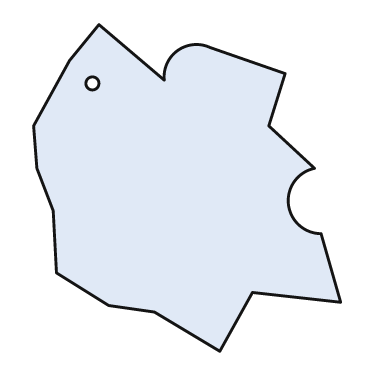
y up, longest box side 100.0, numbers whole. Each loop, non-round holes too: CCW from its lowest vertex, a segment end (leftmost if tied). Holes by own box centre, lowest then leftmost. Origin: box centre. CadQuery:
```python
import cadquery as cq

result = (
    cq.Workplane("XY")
    .moveTo(10.0, -50.0)
    .lineTo(20.0, -32.0)
    .lineTo(47.0, -35.0)
    .lineTo(41.0, -14.0)
    .threePointArc((31.0, -5.0), (39.0, 6.0))
    .lineTo(25.0, 19.0)
    .lineTo(30.0, 35.0)
    .lineTo(7.0, 43.0)
    .threePointArc((-3.0, 42.0), (-7.0, 33.0))
    .lineTo(-27.0, 50.0)
    .lineTo(-36.0, 39.0)
    .lineTo(-47.0, 19.0)
    .lineTo(-46.0, 6.0)
    .lineTo(-41.0, -7.0)
    .lineTo(-40.0, -26.0)
    .lineTo(-24.0, -36.0)
    .lineTo(-10.0, -38.0)
    .close()
    .moveTo(-29.0, 32.0)
    .circle(2.0)
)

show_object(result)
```